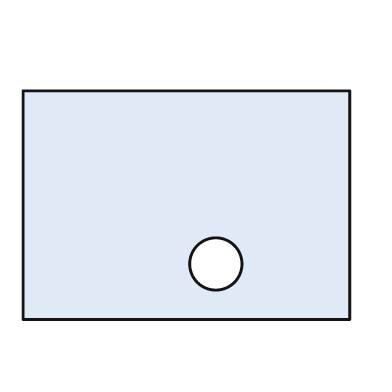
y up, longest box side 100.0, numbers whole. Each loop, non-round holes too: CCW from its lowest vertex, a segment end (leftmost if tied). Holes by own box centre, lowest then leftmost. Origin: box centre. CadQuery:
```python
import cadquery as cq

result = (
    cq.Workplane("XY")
    .moveTo(-50.0, -35.0)
    .lineTo(50.0, -35.0)
    .lineTo(50.0, 35.0)
    .lineTo(-50.0, 35.0)
    .close()
    .moveTo(9.0, -18.0)
    .circle(8.0)
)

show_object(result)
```